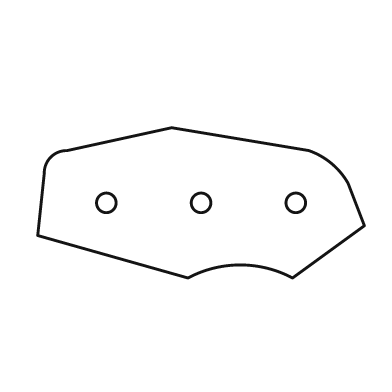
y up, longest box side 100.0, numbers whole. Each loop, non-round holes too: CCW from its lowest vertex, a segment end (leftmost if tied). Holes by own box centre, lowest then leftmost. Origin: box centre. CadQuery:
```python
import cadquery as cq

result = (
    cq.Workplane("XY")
    .moveTo(-4.0, -23.0)
    .threePointArc((12.0, -19.0), (28.0, -23.0))
    .lineTo(50.0, -7.0)
    .lineTo(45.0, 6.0)
    .threePointArc((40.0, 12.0), (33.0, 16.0))
    .lineTo(-9.0, 23.0)
    .lineTo(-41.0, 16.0)
    .threePointArc((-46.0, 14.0), (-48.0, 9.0))
    .lineTo(-50.0, -10.0)
    .close()
    .moveTo(-29.0, 0.0)
    .circle(3.0)
    .moveTo(0.0, 0.0)
    .circle(3.0)
    .moveTo(29.0, 0.0)
    .circle(3.0)
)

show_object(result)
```